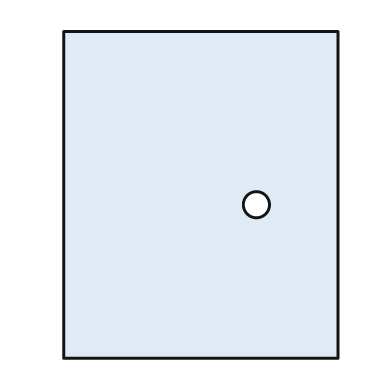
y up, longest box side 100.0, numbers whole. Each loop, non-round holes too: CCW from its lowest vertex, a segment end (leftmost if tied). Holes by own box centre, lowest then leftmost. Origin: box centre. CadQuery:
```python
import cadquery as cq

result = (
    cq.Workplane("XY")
    .moveTo(-42.0, -50.0)
    .lineTo(42.0, -50.0)
    .lineTo(42.0, 50.0)
    .lineTo(-42.0, 50.0)
    .close()
    .moveTo(17.0, -3.0)
    .circle(4.0)
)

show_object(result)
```